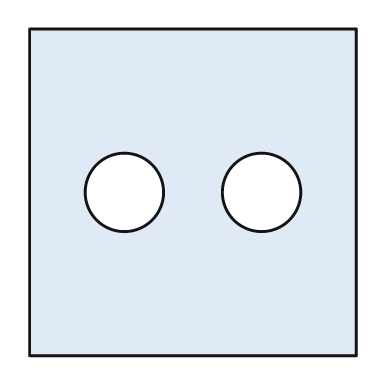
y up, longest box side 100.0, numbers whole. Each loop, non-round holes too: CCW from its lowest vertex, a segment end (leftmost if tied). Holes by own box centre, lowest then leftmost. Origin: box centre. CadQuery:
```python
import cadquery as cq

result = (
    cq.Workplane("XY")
    .moveTo(-50.0, -50.0)
    .lineTo(50.0, -50.0)
    .lineTo(50.0, 50.0)
    .lineTo(-50.0, 50.0)
    .close()
    .moveTo(-21.0, 0.0)
    .circle(12.0)
    .moveTo(21.0, 0.0)
    .circle(12.0)
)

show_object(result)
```